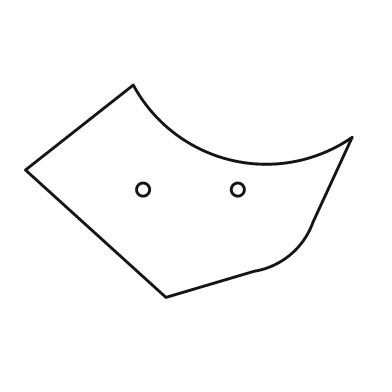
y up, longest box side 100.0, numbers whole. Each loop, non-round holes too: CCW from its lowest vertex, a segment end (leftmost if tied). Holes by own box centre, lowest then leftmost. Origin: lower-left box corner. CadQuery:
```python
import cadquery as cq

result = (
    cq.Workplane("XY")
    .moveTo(43.0, 0.0)
    .lineTo(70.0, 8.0)
    .threePointArc((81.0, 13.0), (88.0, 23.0))
    .lineTo(100.0, 49.0)
    .threePointArc((63.0, 42.0), (33.0, 65.0))
    .lineTo(0.0, 39.0)
    .close()
    .moveTo(36.0, 33.0)
    .circle(2.0)
    .moveTo(65.0, 33.0)
    .circle(2.0)
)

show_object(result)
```